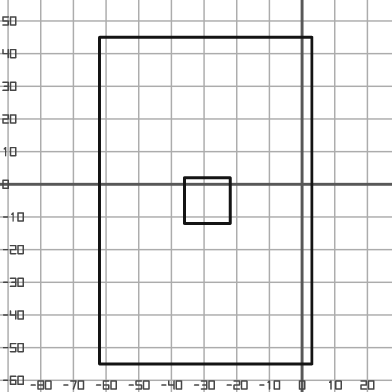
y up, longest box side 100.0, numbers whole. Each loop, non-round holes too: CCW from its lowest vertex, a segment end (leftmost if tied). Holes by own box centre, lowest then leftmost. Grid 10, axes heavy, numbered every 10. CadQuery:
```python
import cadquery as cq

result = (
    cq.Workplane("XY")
    .moveTo(-62.0, -55.0)
    .lineTo(3.0, -55.0)
    .lineTo(3.0, 45.0)
    .lineTo(-62.0, 45.0)
    .close()
    .moveTo(-36.0, -12.0)
    .lineTo(-22.0, -12.0)
    .lineTo(-22.0, 2.0)
    .lineTo(-36.0, 2.0)
    .close()
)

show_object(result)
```